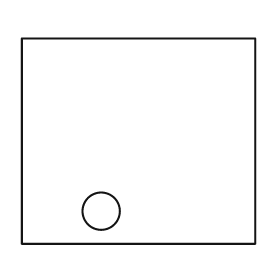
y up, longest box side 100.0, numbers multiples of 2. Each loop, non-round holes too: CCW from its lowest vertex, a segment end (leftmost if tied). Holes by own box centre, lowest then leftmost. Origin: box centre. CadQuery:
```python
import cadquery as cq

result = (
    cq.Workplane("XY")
    .moveTo(-50.0, -44.0)
    .lineTo(50.0, -44.0)
    .lineTo(50.0, 44.0)
    .lineTo(-50.0, 44.0)
    .close()
    .moveTo(-16.0, -30.0)
    .circle(8.0)
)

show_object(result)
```